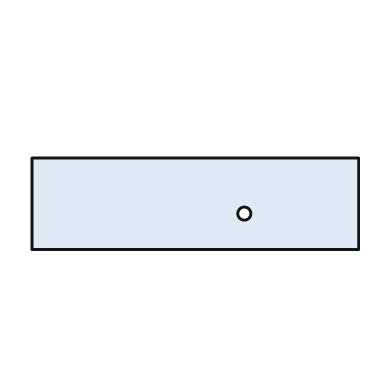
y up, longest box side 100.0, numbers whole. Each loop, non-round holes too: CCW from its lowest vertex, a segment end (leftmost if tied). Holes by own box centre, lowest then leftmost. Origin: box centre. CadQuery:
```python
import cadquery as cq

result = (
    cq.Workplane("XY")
    .moveTo(-50.0, -14.0)
    .lineTo(50.0, -14.0)
    .lineTo(50.0, 14.0)
    .lineTo(-50.0, 14.0)
    .close()
    .moveTo(15.0, -3.0)
    .circle(2.0)
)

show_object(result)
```